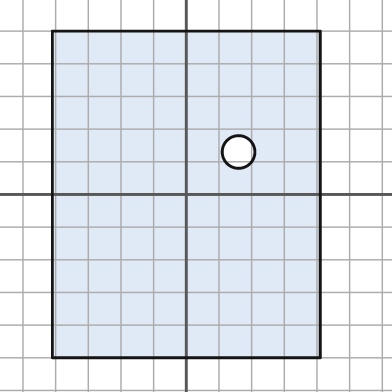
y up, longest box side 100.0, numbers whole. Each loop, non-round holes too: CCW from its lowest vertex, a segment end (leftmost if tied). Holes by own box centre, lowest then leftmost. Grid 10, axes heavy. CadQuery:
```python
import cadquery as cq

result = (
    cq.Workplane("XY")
    .moveTo(-41.0, -50.0)
    .lineTo(41.0, -50.0)
    .lineTo(41.0, 50.0)
    .lineTo(-41.0, 50.0)
    .close()
    .moveTo(16.0, 13.0)
    .circle(5.0)
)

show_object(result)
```